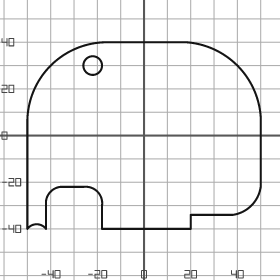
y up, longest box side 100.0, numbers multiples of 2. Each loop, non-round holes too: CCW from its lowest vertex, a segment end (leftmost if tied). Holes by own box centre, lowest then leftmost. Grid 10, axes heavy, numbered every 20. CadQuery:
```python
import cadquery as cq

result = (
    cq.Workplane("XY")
    .moveTo(-50.0, -40.0)
    .threePointArc((-46.0, -38.0), (-42.0, -40.0))
    .lineTo(-42.0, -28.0)
    .threePointArc((-40.0, -24.0), (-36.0, -22.0))
    .lineTo(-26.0, -22.0)
    .threePointArc((-20.0, -24.0), (-18.0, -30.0))
    .lineTo(-18.0, -40.0)
    .lineTo(20.0, -40.0)
    .lineTo(20.0, -34.0)
    .lineTo(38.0, -34.0)
    .threePointArc((46.0, -30.0), (50.0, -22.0))
    .lineTo(50.0, 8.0)
    .threePointArc((40.0, 30.0), (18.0, 40.0))
    .lineTo(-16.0, 40.0)
    .threePointArc((-40.0, 30.0), (-50.0, 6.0))
    .close()
    .moveTo(-22.0, 30.0)
    .circle(4.0)
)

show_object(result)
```